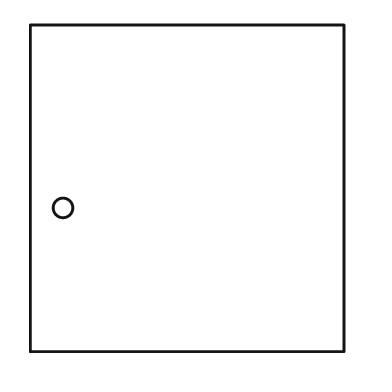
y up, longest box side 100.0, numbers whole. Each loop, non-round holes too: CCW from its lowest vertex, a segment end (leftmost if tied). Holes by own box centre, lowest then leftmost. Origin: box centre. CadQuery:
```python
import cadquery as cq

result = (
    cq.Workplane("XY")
    .moveTo(-48.0, -50.0)
    .lineTo(48.0, -50.0)
    .lineTo(48.0, 50.0)
    .lineTo(-48.0, 50.0)
    .close()
    .moveTo(-38.0, -6.0)
    .circle(3.0)
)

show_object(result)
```